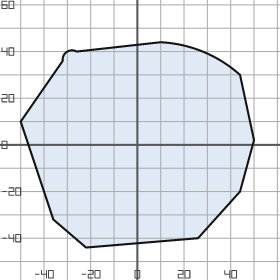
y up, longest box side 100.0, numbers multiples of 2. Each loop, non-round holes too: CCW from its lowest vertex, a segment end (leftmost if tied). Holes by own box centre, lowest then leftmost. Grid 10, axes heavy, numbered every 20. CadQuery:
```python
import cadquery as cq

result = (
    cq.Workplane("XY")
    .moveTo(-22.0, -44.0)
    .lineTo(26.0, -40.0)
    .lineTo(44.0, -20.0)
    .lineTo(50.0, 2.0)
    .lineTo(44.0, 30.0)
    .threePointArc((28.0, 40.0), (10.0, 44.0))
    .lineTo(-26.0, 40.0)
    .threePointArc((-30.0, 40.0), (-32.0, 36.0))
    .lineTo(-50.0, 10.0)
    .lineTo(-36.0, -32.0)
    .close()
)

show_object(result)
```